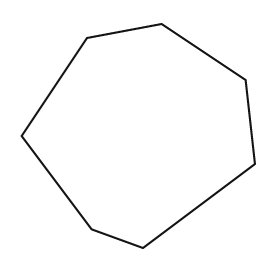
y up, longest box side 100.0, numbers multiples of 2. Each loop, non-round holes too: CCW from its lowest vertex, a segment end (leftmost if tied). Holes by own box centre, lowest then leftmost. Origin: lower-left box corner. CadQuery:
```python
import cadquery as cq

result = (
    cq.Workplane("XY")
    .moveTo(52.0, 0.0)
    .lineTo(100.0, 36.0)
    .lineTo(96.0, 72.0)
    .lineTo(60.0, 96.0)
    .lineTo(28.0, 90.0)
    .lineTo(0.0, 48.0)
    .lineTo(30.0, 8.0)
    .close()
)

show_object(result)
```